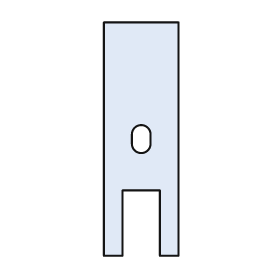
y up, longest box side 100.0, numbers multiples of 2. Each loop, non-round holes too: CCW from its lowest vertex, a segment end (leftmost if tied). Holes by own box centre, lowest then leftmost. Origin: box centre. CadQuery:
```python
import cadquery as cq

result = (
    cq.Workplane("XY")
    .moveTo(-16.0, -50.0)
    .lineTo(-8.0, -50.0)
    .lineTo(-8.0, -22.0)
    .lineTo(8.0, -22.0)
    .lineTo(8.0, -50.0)
    .lineTo(16.0, -50.0)
    .lineTo(16.0, 50.0)
    .lineTo(-16.0, 50.0)
    .close()
    .moveTo(-4.0, -2.0)
    .threePointArc((0.0, -6.0), (4.0, -2.0))
    .lineTo(4.0, 2.0)
    .threePointArc((0.0, 6.0), (-4.0, 2.0))
    .close()
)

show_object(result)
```